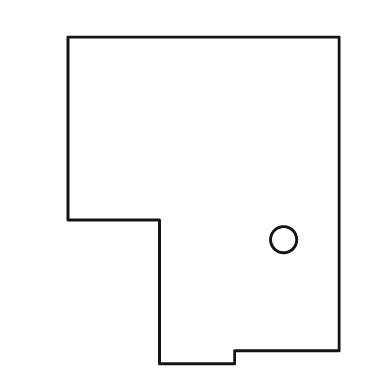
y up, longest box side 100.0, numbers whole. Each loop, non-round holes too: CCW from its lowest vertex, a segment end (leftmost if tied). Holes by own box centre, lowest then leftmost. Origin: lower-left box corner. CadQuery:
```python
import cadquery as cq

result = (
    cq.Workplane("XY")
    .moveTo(28.0, 0.0)
    .lineTo(51.0, 0.0)
    .lineTo(51.0, 4.0)
    .lineTo(83.0, 4.0)
    .lineTo(83.0, 100.0)
    .lineTo(0.0, 100.0)
    .lineTo(0.0, 44.0)
    .lineTo(28.0, 44.0)
    .close()
    .moveTo(66.0, 38.0)
    .circle(4.0)
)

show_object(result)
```